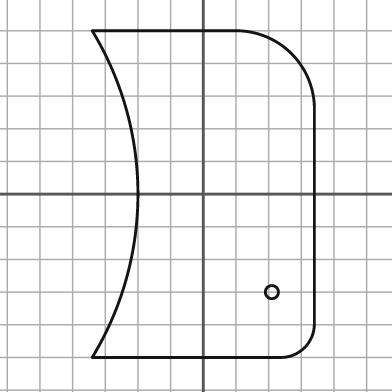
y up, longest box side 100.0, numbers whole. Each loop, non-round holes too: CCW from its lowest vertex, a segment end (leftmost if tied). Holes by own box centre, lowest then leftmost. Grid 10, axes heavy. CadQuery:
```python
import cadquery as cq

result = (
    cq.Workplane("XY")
    .moveTo(-34.0, -50.0)
    .lineTo(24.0, -50.0)
    .threePointArc((31.0, -47.0), (34.0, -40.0))
    .lineTo(34.0, 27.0)
    .threePointArc((27.0, 43.0), (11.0, 50.0))
    .lineTo(-34.0, 50.0)
    .threePointArc((-20.0, 0.0), (-34.0, -50.0))
    .close()
    .moveTo(21.0, -30.0)
    .circle(2.0)
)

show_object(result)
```